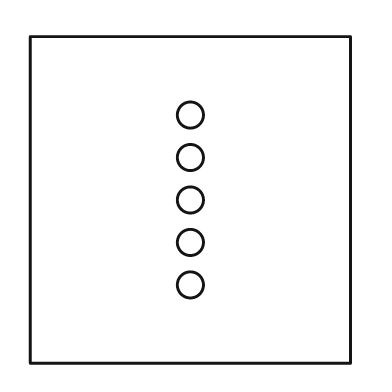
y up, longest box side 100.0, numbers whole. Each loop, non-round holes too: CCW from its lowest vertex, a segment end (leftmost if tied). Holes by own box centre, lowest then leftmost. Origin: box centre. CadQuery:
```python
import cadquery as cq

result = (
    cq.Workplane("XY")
    .moveTo(-49.0, -50.0)
    .lineTo(49.0, -50.0)
    .lineTo(49.0, 50.0)
    .lineTo(-49.0, 50.0)
    .close()
    .moveTo(0.0, -26.0)
    .circle(4.0)
    .moveTo(0.0, -13.0)
    .circle(4.0)
    .moveTo(0.0, 0.0)
    .circle(4.0)
    .moveTo(0.0, 13.0)
    .circle(4.0)
    .moveTo(0.0, 26.0)
    .circle(4.0)
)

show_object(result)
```